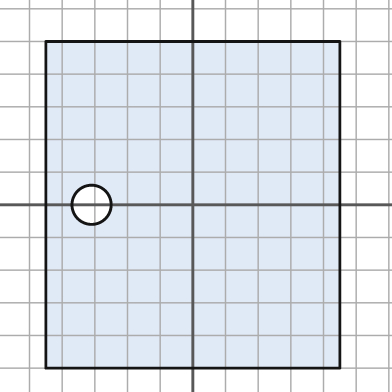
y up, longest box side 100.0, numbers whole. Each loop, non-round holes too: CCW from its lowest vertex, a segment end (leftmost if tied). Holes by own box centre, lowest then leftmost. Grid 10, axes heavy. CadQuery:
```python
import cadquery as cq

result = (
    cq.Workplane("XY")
    .moveTo(-45.0, -50.0)
    .lineTo(45.0, -50.0)
    .lineTo(45.0, 50.0)
    .lineTo(-45.0, 50.0)
    .close()
    .moveTo(-31.0, 0.0)
    .circle(6.0)
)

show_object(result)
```